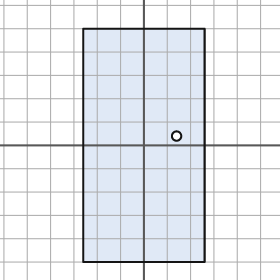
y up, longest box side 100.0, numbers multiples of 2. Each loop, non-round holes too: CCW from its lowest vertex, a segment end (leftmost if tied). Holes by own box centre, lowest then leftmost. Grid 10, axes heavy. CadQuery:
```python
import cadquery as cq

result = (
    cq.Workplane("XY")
    .moveTo(-26.0, -50.0)
    .lineTo(26.0, -50.0)
    .lineTo(26.0, 50.0)
    .lineTo(-26.0, 50.0)
    .close()
    .moveTo(14.0, 4.0)
    .circle(2.0)
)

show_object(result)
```